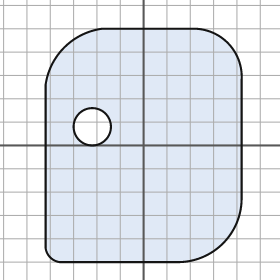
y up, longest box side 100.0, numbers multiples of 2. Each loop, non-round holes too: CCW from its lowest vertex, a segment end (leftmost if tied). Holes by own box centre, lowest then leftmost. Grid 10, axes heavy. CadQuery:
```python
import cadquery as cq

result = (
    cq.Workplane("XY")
    .moveTo(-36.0, -50.0)
    .lineTo(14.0, -50.0)
    .threePointArc((34.0, -42.0), (42.0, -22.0))
    .lineTo(42.0, 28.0)
    .threePointArc((36.0, 44.0), (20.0, 50.0))
    .lineTo(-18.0, 50.0)
    .threePointArc((-34.0, 42.0), (-42.0, 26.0))
    .lineTo(-42.0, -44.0)
    .threePointArc((-40.0, -48.0), (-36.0, -50.0))
    .close()
    .moveTo(-22.0, 8.0)
    .circle(8.0)
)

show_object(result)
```